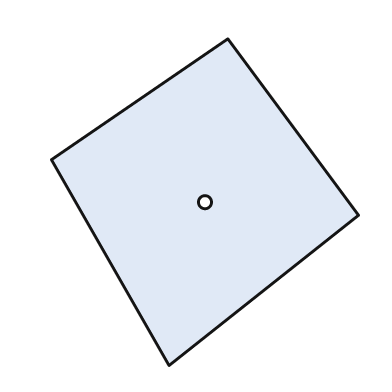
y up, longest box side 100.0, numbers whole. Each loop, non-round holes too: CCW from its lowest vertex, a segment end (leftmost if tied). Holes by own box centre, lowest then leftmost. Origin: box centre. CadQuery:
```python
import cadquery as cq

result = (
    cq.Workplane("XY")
    .moveTo(-11.0, -50.0)
    .lineTo(47.0, -4.0)
    .lineTo(7.0, 50.0)
    .lineTo(-47.0, 13.0)
    .close()
    .moveTo(0.0, 0.0)
    .circle(2.0)
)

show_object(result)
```